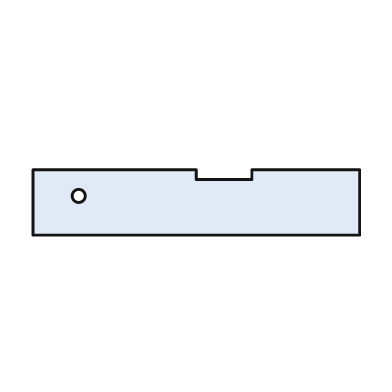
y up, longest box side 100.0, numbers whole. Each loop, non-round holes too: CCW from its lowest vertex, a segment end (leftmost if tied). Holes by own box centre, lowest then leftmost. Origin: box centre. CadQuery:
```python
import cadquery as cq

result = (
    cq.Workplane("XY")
    .moveTo(-50.0, -10.0)
    .lineTo(50.0, -10.0)
    .lineTo(50.0, 10.0)
    .lineTo(17.0, 10.0)
    .lineTo(17.0, 7.0)
    .lineTo(0.0, 7.0)
    .lineTo(0.0, 10.0)
    .lineTo(-50.0, 10.0)
    .close()
    .moveTo(-36.0, 2.0)
    .circle(2.0)
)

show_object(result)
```